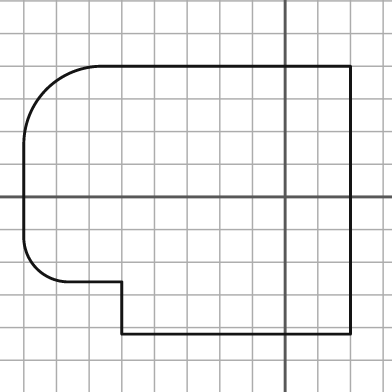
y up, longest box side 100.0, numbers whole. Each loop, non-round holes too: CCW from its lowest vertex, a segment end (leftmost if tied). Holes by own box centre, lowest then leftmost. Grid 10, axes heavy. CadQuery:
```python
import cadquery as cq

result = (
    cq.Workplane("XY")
    .moveTo(-50.0, -42.0)
    .lineTo(20.0, -42.0)
    .lineTo(20.0, 40.0)
    .lineTo(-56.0, 40.0)
    .threePointArc((-73.0, 33.0), (-80.0, 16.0))
    .lineTo(-80.0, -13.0)
    .threePointArc((-76.0, -22.0), (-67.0, -26.0))
    .lineTo(-50.0, -26.0)
    .close()
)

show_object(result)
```